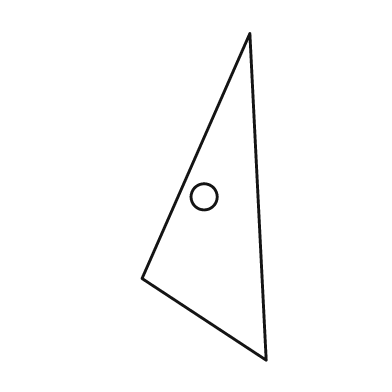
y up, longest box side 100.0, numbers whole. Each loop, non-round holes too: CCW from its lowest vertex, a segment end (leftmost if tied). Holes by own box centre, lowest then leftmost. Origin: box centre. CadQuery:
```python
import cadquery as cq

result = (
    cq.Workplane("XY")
    .moveTo(19.0, -50.0)
    .lineTo(14.0, 50.0)
    .lineTo(-19.0, -25.0)
    .close()
    .moveTo(0.0, 0.0)
    .circle(4.0)
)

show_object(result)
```